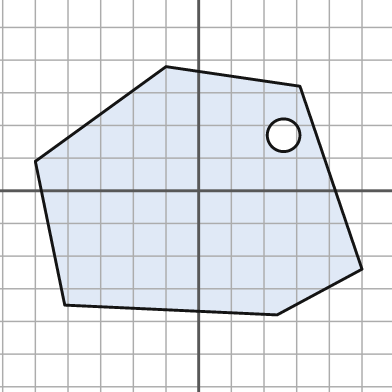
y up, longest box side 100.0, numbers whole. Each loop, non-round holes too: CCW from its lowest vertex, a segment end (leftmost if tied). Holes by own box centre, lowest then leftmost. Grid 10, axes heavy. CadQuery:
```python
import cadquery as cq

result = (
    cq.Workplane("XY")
    .moveTo(24.0, -38.0)
    .lineTo(50.0, -24.0)
    .lineTo(31.0, 32.0)
    .lineTo(-10.0, 38.0)
    .lineTo(-50.0, 9.0)
    .lineTo(-41.0, -35.0)
    .close()
    .moveTo(26.0, 17.0)
    .circle(5.0)
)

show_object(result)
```